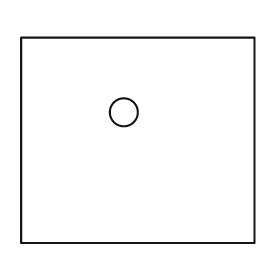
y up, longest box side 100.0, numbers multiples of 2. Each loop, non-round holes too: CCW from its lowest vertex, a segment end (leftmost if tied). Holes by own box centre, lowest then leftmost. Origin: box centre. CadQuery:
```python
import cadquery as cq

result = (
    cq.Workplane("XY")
    .moveTo(-50.0, -44.0)
    .lineTo(50.0, -44.0)
    .lineTo(50.0, 44.0)
    .lineTo(-50.0, 44.0)
    .close()
    .moveTo(-6.0, 12.0)
    .circle(6.0)
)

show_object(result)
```